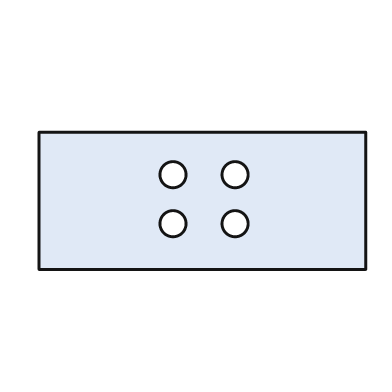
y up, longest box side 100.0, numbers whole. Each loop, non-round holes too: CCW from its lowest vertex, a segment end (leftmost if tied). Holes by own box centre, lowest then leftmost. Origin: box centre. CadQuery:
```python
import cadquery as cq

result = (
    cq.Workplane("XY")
    .moveTo(-50.0, -21.0)
    .lineTo(50.0, -21.0)
    .lineTo(50.0, 21.0)
    .lineTo(-50.0, 21.0)
    .close()
    .moveTo(-9.0, -7.0)
    .circle(4.0)
    .moveTo(10.0, -7.0)
    .circle(4.0)
    .moveTo(-9.0, 8.0)
    .circle(4.0)
    .moveTo(10.0, 8.0)
    .circle(4.0)
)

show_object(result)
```